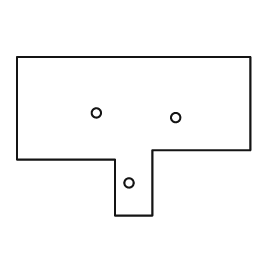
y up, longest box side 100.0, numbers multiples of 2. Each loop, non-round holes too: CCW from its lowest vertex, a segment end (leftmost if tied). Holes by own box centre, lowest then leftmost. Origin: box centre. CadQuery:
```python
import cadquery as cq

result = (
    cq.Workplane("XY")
    .moveTo(-8.0, -34.0)
    .lineTo(8.0, -34.0)
    .lineTo(8.0, -6.0)
    .lineTo(50.0, -6.0)
    .lineTo(50.0, 34.0)
    .lineTo(-50.0, 34.0)
    .lineTo(-50.0, -10.0)
    .lineTo(-8.0, -10.0)
    .close()
    .moveTo(-2.0, -20.0)
    .circle(2.0)
    .moveTo(18.0, 8.0)
    .circle(2.0)
    .moveTo(-16.0, 10.0)
    .circle(2.0)
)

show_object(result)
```